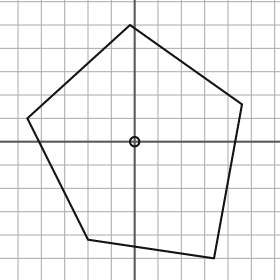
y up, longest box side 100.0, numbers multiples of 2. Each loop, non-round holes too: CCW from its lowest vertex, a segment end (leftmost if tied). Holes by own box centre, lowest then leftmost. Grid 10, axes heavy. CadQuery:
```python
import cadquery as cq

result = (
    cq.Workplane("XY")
    .moveTo(34.0, -50.0)
    .lineTo(46.0, 16.0)
    .lineTo(-2.0, 50.0)
    .lineTo(-46.0, 10.0)
    .lineTo(-20.0, -42.0)
    .close()
    .moveTo(0.0, 0.0)
    .circle(2.0)
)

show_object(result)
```